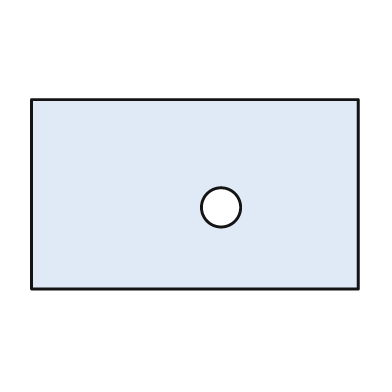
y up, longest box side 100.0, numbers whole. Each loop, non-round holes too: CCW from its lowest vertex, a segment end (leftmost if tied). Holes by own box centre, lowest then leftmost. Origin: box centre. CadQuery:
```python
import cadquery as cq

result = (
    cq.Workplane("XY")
    .moveTo(-50.0, -29.0)
    .lineTo(50.0, -29.0)
    .lineTo(50.0, 29.0)
    .lineTo(-50.0, 29.0)
    .close()
    .moveTo(8.0, -4.0)
    .circle(6.0)
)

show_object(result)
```